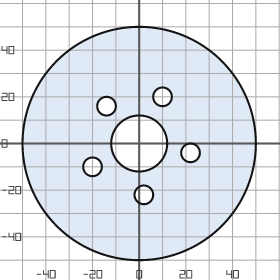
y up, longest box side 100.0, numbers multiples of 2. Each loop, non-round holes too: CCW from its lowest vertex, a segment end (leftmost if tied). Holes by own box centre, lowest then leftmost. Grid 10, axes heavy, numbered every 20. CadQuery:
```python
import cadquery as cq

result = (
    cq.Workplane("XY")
    .moveTo(0.0, 0.0)
    .circle(50.0)
    .moveTo(2.0, -22.0)
    .circle(4.0)
    .moveTo(-20.0, -10.0)
    .circle(4.0)
    .moveTo(22.0, -4.0)
    .circle(4.0)
    .moveTo(0.0, 0.0)
    .circle(12.0)
    .moveTo(-14.0, 16.0)
    .circle(4.0)
    .moveTo(10.0, 20.0)
    .circle(4.0)
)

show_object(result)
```